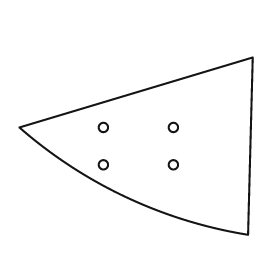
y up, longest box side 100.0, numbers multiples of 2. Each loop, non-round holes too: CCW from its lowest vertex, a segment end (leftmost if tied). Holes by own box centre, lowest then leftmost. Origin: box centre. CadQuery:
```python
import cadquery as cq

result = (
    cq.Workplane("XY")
    .moveTo(48.0, -38.0)
    .lineTo(50.0, 38.0)
    .lineTo(-50.0, 8.0)
    .threePointArc((-4.0, -22.0), (48.0, -38.0))
    .close()
    .moveTo(-14.0, -8.0)
    .circle(2.0)
    .moveTo(16.0, -8.0)
    .circle(2.0)
    .moveTo(-14.0, 8.0)
    .circle(2.0)
    .moveTo(16.0, 8.0)
    .circle(2.0)
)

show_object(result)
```